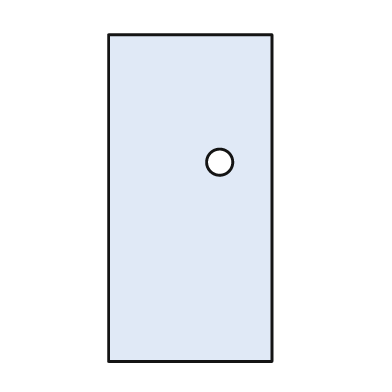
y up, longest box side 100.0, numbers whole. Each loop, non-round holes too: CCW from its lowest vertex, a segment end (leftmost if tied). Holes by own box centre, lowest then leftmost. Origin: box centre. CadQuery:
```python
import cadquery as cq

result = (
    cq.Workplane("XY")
    .moveTo(-25.0, -50.0)
    .lineTo(25.0, -50.0)
    .lineTo(25.0, 50.0)
    .lineTo(-25.0, 50.0)
    .close()
    .moveTo(9.0, 11.0)
    .circle(4.0)
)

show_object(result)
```